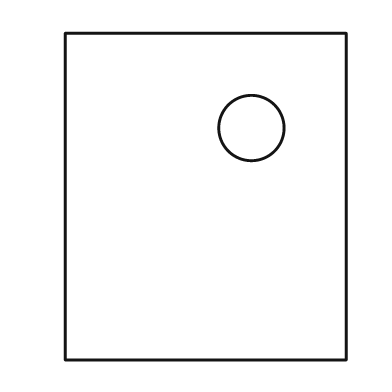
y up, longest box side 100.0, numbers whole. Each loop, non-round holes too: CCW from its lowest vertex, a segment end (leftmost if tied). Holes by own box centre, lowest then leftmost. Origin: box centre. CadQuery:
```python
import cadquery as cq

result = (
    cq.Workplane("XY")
    .moveTo(-43.0, -50.0)
    .lineTo(43.0, -50.0)
    .lineTo(43.0, 50.0)
    .lineTo(-43.0, 50.0)
    .close()
    .moveTo(14.0, 21.0)
    .circle(10.0)
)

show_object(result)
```